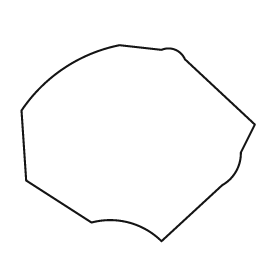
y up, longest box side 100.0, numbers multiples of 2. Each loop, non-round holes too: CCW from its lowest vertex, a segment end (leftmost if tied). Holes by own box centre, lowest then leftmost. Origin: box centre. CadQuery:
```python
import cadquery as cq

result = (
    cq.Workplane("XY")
    .moveTo(10.0, -42.0)
    .lineTo(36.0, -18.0)
    .threePointArc((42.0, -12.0), (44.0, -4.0))
    .lineTo(50.0, 8.0)
    .lineTo(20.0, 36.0)
    .threePointArc((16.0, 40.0), (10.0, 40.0))
    .lineTo(-8.0, 42.0)
    .threePointArc((-32.0, 32.0), (-50.0, 14.0))
    .lineTo(-48.0, -16.0)
    .lineTo(-20.0, -34.0)
    .threePointArc((-4.0, -34.0), (10.0, -42.0))
    .close()
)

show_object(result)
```